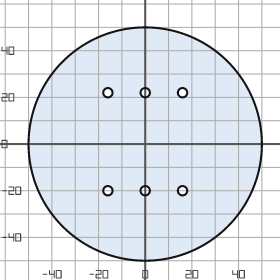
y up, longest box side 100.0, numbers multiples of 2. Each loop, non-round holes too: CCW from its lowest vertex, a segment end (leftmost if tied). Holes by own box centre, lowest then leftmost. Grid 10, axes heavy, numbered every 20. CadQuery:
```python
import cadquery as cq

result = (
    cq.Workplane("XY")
    .moveTo(0.0, 0.0)
    .circle(50.0)
    .moveTo(-16.0, -20.0)
    .circle(2.0)
    .moveTo(0.0, -20.0)
    .circle(2.0)
    .moveTo(16.0, -20.0)
    .circle(2.0)
    .moveTo(-16.0, 22.0)
    .circle(2.0)
    .moveTo(0.0, 22.0)
    .circle(2.0)
    .moveTo(16.0, 22.0)
    .circle(2.0)
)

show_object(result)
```